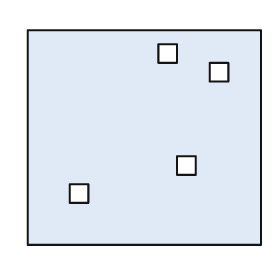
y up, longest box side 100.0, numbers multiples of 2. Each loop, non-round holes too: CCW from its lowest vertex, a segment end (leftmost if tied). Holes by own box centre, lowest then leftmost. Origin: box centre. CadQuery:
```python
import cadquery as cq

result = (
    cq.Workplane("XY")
    .moveTo(-50.0, -46.0)
    .lineTo(50.0, -46.0)
    .lineTo(50.0, 46.0)
    .lineTo(-50.0, 46.0)
    .close()
    .moveTo(-32.0, -28.0)
    .lineTo(-24.0, -28.0)
    .lineTo(-24.0, -20.0)
    .lineTo(-32.0, -20.0)
    .close()
    .moveTo(14.0, -16.0)
    .lineTo(22.0, -16.0)
    .lineTo(22.0, -8.0)
    .lineTo(14.0, -8.0)
    .close()
    .moveTo(28.0, 24.0)
    .lineTo(36.0, 24.0)
    .lineTo(36.0, 32.0)
    .lineTo(28.0, 32.0)
    .close()
    .moveTo(6.0, 32.0)
    .lineTo(14.0, 32.0)
    .lineTo(14.0, 40.0)
    .lineTo(6.0, 40.0)
    .close()
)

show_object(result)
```